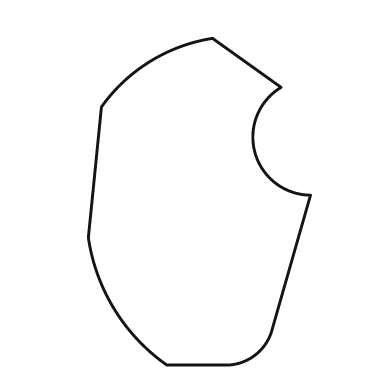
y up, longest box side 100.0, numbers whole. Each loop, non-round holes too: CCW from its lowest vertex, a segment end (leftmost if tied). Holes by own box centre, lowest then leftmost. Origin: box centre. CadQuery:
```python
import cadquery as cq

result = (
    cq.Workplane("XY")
    .moveTo(-10.0, -50.0)
    .lineTo(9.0, -50.0)
    .threePointArc((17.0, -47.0), (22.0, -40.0))
    .lineTo(34.0, 2.0)
    .threePointArc((17.0, 15.0), (25.0, 35.0))
    .lineTo(4.0, 50.0)
    .threePointArc((-15.0, 43.0), (-30.0, 29.0))
    .lineTo(-34.0, -11.0)
    .threePointArc((-26.0, -33.0), (-10.0, -50.0))
    .close()
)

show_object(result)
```